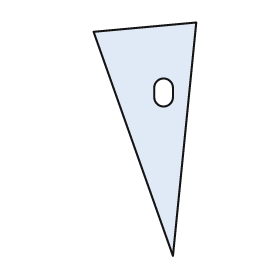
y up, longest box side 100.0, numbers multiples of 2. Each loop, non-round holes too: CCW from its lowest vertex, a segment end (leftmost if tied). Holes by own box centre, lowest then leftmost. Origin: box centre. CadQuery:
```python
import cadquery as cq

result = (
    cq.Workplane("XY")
    .moveTo(12.0, -50.0)
    .lineTo(22.0, 50.0)
    .lineTo(-22.0, 46.0)
    .close()
    .moveTo(4.0, 18.0)
    .threePointArc((8.0, 14.0), (12.0, 18.0))
    .lineTo(12.0, 22.0)
    .threePointArc((8.0, 26.0), (4.0, 22.0))
    .close()
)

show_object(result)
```